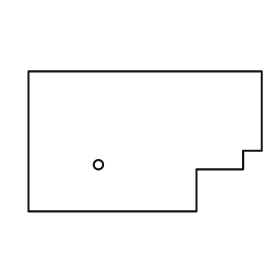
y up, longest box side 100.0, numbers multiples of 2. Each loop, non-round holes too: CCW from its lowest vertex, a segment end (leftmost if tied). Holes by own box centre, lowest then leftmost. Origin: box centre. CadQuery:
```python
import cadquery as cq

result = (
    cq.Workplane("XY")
    .moveTo(-50.0, -30.0)
    .lineTo(22.0, -30.0)
    .lineTo(22.0, -12.0)
    .lineTo(42.0, -12.0)
    .lineTo(42.0, -4.0)
    .lineTo(50.0, -4.0)
    .lineTo(50.0, 30.0)
    .lineTo(-50.0, 30.0)
    .close()
    .moveTo(-20.0, -10.0)
    .circle(2.0)
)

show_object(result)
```